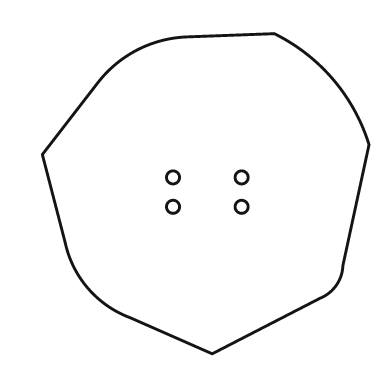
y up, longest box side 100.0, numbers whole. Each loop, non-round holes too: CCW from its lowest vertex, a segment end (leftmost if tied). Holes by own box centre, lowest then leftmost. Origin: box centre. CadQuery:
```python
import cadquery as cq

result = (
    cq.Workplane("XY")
    .moveTo(2.0, -49.0)
    .lineTo(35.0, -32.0)
    .threePointArc((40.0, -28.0), (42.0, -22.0))
    .lineTo(50.0, 15.0)
    .threePointArc((39.0, 35.0), (21.0, 49.0))
    .lineTo(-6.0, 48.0)
    .threePointArc((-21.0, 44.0), (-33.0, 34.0))
    .lineTo(-50.0, 12.0)
    .lineTo(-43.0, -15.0)
    .threePointArc((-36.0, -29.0), (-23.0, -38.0))
    .close()
    .moveTo(-10.0, -4.0)
    .circle(2.0)
    .moveTo(11.0, -4.0)
    .circle(2.0)
    .moveTo(-10.0, 5.0)
    .circle(2.0)
    .moveTo(11.0, 5.0)
    .circle(2.0)
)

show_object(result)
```